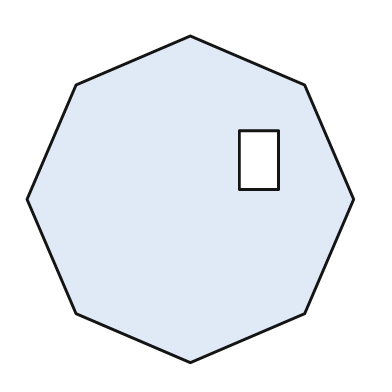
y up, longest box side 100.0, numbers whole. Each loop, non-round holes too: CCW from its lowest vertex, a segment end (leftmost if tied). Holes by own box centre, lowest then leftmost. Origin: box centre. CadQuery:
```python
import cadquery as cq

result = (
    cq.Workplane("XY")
    .moveTo(0.0, -50.0)
    .lineTo(35.0, -35.0)
    .lineTo(50.0, 0.0)
    .lineTo(35.0, 35.0)
    .lineTo(0.0, 50.0)
    .lineTo(-35.0, 35.0)
    .lineTo(-50.0, 0.0)
    .lineTo(-35.0, -35.0)
    .close()
    .moveTo(15.0, 3.0)
    .lineTo(27.0, 3.0)
    .lineTo(27.0, 21.0)
    .lineTo(15.0, 21.0)
    .close()
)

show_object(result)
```